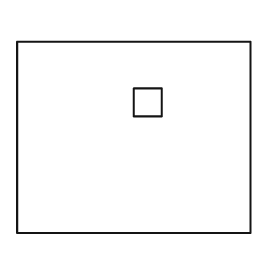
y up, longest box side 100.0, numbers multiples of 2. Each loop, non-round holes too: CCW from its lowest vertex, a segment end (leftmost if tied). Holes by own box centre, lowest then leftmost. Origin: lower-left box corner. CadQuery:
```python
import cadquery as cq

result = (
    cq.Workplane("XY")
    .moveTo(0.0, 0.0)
    .lineTo(100.0, 0.0)
    .lineTo(100.0, 82.0)
    .lineTo(0.0, 82.0)
    .close()
    .moveTo(50.0, 50.0)
    .lineTo(62.0, 50.0)
    .lineTo(62.0, 62.0)
    .lineTo(50.0, 62.0)
    .close()
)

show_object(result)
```